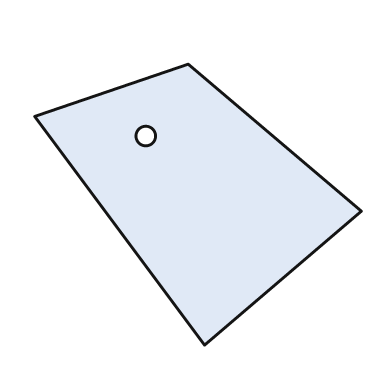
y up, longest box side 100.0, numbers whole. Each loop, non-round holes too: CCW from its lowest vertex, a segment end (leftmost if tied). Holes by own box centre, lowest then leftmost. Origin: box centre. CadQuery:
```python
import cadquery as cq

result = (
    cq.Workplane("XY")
    .moveTo(2.0, -43.0)
    .lineTo(50.0, -2.0)
    .lineTo(-3.0, 43.0)
    .lineTo(-50.0, 27.0)
    .close()
    .moveTo(-16.0, 21.0)
    .circle(3.0)
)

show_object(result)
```